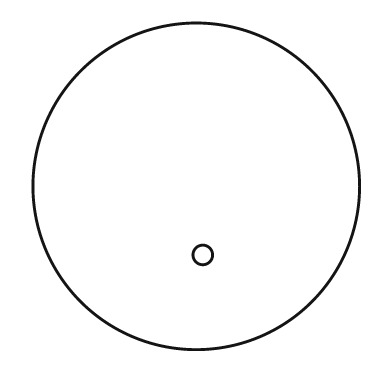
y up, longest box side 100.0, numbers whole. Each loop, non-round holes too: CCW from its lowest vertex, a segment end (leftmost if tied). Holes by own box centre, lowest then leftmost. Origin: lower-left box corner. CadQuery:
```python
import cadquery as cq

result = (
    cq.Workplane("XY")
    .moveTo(50.0, 50.0)
    .circle(50.0)
    .moveTo(52.0, 29.0)
    .circle(3.0)
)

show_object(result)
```